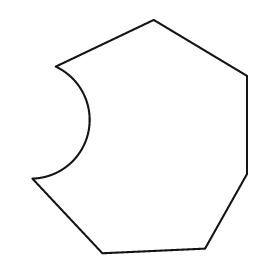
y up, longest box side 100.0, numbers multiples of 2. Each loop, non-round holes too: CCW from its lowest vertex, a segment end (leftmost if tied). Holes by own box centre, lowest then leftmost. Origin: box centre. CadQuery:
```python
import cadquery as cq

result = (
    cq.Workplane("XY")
    .moveTo(-16.0, -50.0)
    .lineTo(28.0, -48.0)
    .lineTo(46.0, -16.0)
    .lineTo(46.0, 26.0)
    .lineTo(6.0, 50.0)
    .lineTo(-36.0, 30.0)
    .threePointArc((-22.0, 2.0), (-46.0, -18.0))
    .close()
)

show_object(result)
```